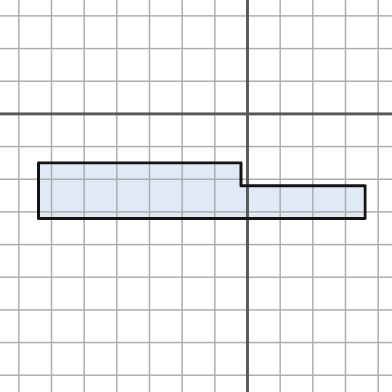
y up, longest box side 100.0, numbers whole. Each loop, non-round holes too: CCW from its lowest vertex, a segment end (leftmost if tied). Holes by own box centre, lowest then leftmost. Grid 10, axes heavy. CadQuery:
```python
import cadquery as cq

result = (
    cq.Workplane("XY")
    .moveTo(-64.0, -32.0)
    .lineTo(36.0, -32.0)
    .lineTo(36.0, -22.0)
    .lineTo(-2.0, -22.0)
    .lineTo(-2.0, -15.0)
    .lineTo(-64.0, -15.0)
    .close()
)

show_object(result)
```